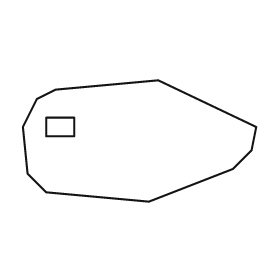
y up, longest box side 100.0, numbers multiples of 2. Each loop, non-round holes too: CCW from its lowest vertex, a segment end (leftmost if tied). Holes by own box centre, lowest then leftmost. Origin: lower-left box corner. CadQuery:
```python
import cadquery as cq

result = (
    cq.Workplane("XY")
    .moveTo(54.0, 0.0)
    .lineTo(90.0, 14.0)
    .lineTo(98.0, 22.0)
    .lineTo(100.0, 32.0)
    .lineTo(58.0, 52.0)
    .lineTo(14.0, 48.0)
    .lineTo(6.0, 44.0)
    .lineTo(0.0, 32.0)
    .lineTo(2.0, 12.0)
    .lineTo(10.0, 4.0)
    .close()
    .moveTo(10.0, 28.0)
    .lineTo(22.0, 28.0)
    .lineTo(22.0, 36.0)
    .lineTo(10.0, 36.0)
    .close()
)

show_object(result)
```